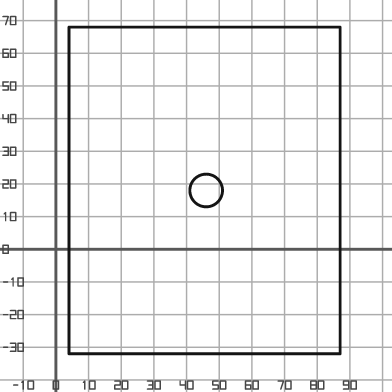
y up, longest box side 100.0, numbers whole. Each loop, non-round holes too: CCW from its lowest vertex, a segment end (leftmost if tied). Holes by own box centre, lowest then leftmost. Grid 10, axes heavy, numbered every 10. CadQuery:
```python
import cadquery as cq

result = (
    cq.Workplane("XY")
    .moveTo(4.0, -32.0)
    .lineTo(87.0, -32.0)
    .lineTo(87.0, 68.0)
    .lineTo(4.0, 68.0)
    .close()
    .moveTo(46.0, 18.0)
    .circle(5.0)
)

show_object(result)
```